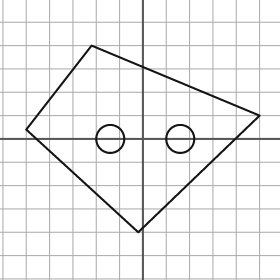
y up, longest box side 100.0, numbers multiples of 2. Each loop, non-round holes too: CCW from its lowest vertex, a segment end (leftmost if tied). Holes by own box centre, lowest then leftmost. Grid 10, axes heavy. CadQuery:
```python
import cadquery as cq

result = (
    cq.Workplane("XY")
    .moveTo(-2.0, -40.0)
    .lineTo(50.0, 10.0)
    .lineTo(-22.0, 40.0)
    .lineTo(-50.0, 4.0)
    .close()
    .moveTo(-14.0, 0.0)
    .circle(6.0)
    .moveTo(16.0, 0.0)
    .circle(6.0)
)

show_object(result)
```